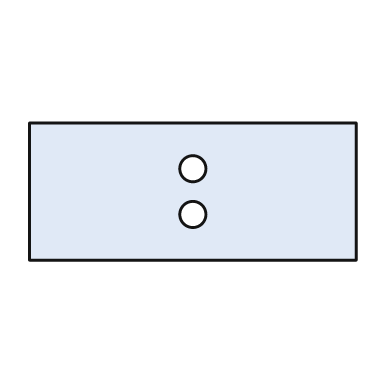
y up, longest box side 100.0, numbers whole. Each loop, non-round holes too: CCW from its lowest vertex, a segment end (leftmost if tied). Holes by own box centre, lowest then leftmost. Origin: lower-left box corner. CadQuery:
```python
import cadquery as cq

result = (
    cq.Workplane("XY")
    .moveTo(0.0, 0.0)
    .lineTo(100.0, 0.0)
    .lineTo(100.0, 42.0)
    .lineTo(0.0, 42.0)
    .close()
    .moveTo(50.0, 14.0)
    .circle(4.0)
    .moveTo(50.0, 28.0)
    .circle(4.0)
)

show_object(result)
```